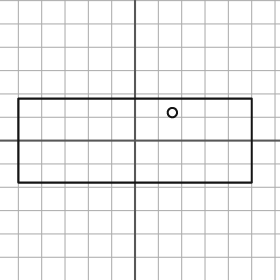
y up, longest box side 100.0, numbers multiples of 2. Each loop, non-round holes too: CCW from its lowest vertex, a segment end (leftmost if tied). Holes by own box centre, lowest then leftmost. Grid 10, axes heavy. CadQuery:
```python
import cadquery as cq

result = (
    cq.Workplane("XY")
    .moveTo(-50.0, -18.0)
    .lineTo(50.0, -18.0)
    .lineTo(50.0, 18.0)
    .lineTo(-50.0, 18.0)
    .close()
    .moveTo(16.0, 12.0)
    .circle(2.0)
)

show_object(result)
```